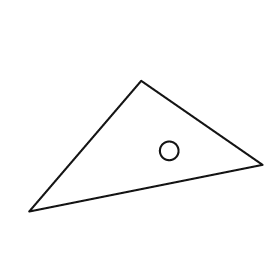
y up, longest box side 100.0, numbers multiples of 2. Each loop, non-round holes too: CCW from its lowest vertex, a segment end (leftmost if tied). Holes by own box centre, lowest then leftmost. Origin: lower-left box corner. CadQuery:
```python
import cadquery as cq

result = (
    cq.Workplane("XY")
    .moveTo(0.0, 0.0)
    .lineTo(100.0, 20.0)
    .lineTo(48.0, 56.0)
    .close()
    .moveTo(60.0, 26.0)
    .circle(4.0)
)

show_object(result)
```